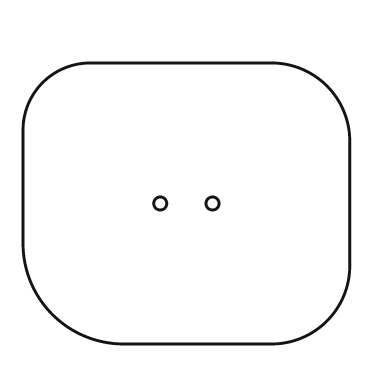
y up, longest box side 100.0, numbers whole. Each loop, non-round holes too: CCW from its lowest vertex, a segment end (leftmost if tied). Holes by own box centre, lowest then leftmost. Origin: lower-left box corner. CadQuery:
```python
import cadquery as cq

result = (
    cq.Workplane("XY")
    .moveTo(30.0, 0.0)
    .lineTo(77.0, 0.0)
    .threePointArc((93.0, 7.0), (100.0, 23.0))
    .lineTo(100.0, 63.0)
    .threePointArc((93.0, 79.0), (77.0, 86.0))
    .lineTo(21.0, 86.0)
    .threePointArc((6.0, 80.0), (0.0, 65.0))
    .lineTo(0.0, 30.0)
    .threePointArc((9.0, 9.0), (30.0, 0.0))
    .close()
    .moveTo(42.0, 43.0)
    .circle(2.0)
    .moveTo(58.0, 43.0)
    .circle(2.0)
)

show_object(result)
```